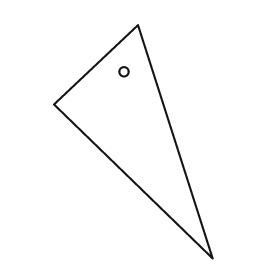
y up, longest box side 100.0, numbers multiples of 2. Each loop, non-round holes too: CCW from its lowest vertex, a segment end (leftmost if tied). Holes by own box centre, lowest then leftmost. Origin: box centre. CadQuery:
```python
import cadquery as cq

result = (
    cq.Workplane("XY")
    .moveTo(34.0, -50.0)
    .lineTo(2.0, 50.0)
    .lineTo(-34.0, 16.0)
    .close()
    .moveTo(-4.0, 30.0)
    .circle(2.0)
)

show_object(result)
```